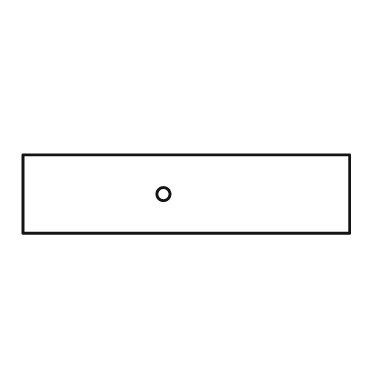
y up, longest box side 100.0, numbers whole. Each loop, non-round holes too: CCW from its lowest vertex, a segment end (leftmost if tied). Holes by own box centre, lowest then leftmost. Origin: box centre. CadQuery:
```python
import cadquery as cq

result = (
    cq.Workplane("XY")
    .moveTo(-50.0, -12.0)
    .lineTo(50.0, -12.0)
    .lineTo(50.0, 12.0)
    .lineTo(-50.0, 12.0)
    .close()
    .moveTo(-7.0, 0.0)
    .circle(2.0)
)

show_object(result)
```